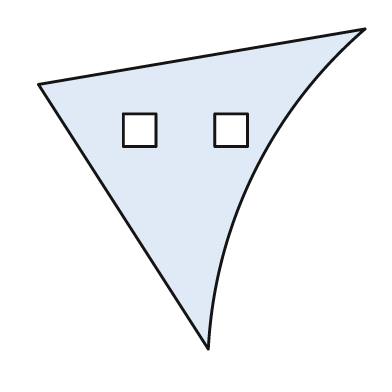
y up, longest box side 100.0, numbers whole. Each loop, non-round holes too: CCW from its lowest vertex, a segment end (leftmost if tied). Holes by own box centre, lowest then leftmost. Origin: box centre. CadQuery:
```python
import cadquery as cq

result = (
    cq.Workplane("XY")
    .moveTo(2.0, -49.0)
    .threePointArc((16.0, 5.0), (50.0, 49.0))
    .lineTo(-50.0, 32.0)
    .close()
    .moveTo(-24.0, 13.0)
    .lineTo(-14.0, 13.0)
    .lineTo(-14.0, 23.0)
    .lineTo(-24.0, 23.0)
    .close()
    .moveTo(4.0, 13.0)
    .lineTo(14.0, 13.0)
    .lineTo(14.0, 23.0)
    .lineTo(4.0, 23.0)
    .close()
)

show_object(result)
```